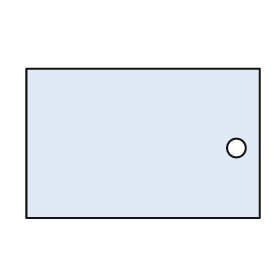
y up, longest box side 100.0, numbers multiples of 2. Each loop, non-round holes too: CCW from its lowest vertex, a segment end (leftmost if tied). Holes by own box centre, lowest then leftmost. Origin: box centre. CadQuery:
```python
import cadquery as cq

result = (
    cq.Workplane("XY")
    .moveTo(-50.0, -32.0)
    .lineTo(50.0, -32.0)
    .lineTo(50.0, 32.0)
    .lineTo(-50.0, 32.0)
    .close()
    .moveTo(40.0, -2.0)
    .circle(4.0)
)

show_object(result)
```